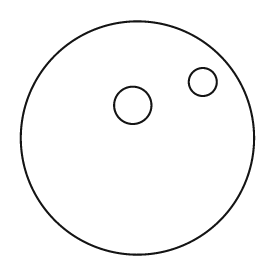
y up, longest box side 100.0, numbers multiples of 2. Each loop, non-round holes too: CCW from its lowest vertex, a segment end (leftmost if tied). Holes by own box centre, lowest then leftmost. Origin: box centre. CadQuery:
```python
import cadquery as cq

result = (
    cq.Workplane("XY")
    .moveTo(0.0, 0.0)
    .circle(50.0)
    .moveTo(-2.0, 14.0)
    .circle(8.0)
    .moveTo(28.0, 24.0)
    .circle(6.0)
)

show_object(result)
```